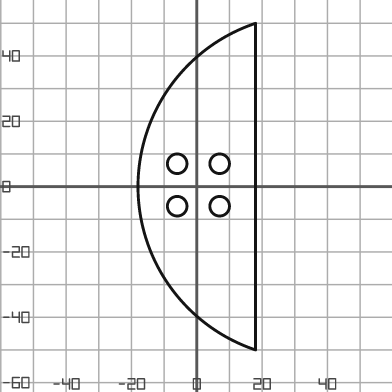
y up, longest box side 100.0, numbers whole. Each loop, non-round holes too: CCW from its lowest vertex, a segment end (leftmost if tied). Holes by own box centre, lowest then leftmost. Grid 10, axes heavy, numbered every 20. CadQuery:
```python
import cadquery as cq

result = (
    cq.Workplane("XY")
    .moveTo(18.0, -50.0)
    .lineTo(18.0, 50.0)
    .threePointArc((-18.0, 0.0), (18.0, -50.0))
    .close()
    .moveTo(-6.0, -6.0)
    .circle(3.0)
    .moveTo(7.0, -6.0)
    .circle(3.0)
    .moveTo(-6.0, 7.0)
    .circle(3.0)
    .moveTo(7.0, 7.0)
    .circle(3.0)
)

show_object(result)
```